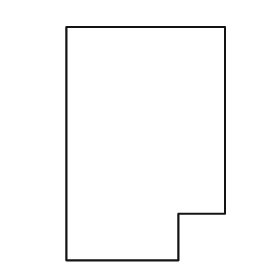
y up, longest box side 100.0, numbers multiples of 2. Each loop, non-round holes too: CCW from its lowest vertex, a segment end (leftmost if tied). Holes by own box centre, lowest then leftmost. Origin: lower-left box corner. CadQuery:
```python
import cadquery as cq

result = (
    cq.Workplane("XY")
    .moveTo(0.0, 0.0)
    .lineTo(48.0, 0.0)
    .lineTo(48.0, 20.0)
    .lineTo(68.0, 20.0)
    .lineTo(68.0, 100.0)
    .lineTo(0.0, 100.0)
    .close()
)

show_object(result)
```